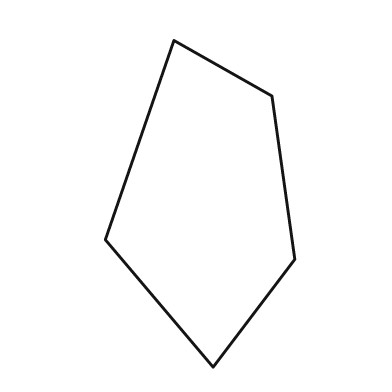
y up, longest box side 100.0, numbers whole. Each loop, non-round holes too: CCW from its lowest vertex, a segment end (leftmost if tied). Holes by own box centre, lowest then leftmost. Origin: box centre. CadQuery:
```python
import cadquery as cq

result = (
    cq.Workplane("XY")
    .moveTo(4.0, -50.0)
    .lineTo(29.0, -17.0)
    .lineTo(22.0, 33.0)
    .lineTo(-8.0, 50.0)
    .lineTo(-29.0, -11.0)
    .close()
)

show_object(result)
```